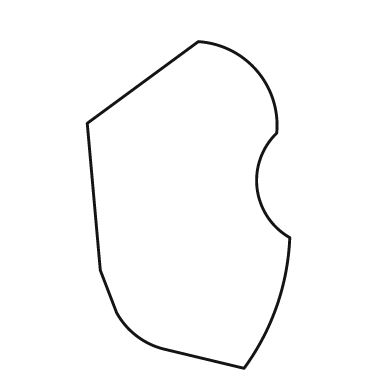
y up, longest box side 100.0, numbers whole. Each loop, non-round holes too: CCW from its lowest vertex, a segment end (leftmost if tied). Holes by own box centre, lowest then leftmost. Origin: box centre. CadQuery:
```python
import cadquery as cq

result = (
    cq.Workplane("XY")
    .moveTo(17.0, -50.0)
    .threePointArc((27.0, -31.0), (31.0, -10.0))
    .threePointArc((21.0, 5.0), (27.0, 22.0))
    .threePointArc((21.0, 41.0), (3.0, 50.0))
    .lineTo(-31.0, 25.0)
    .lineTo(-27.0, -20.0)
    .lineTo(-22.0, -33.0)
    .threePointArc((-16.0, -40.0), (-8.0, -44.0))
    .close()
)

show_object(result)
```